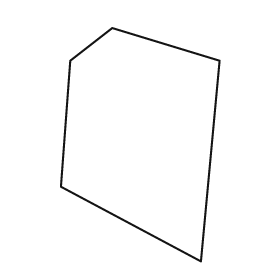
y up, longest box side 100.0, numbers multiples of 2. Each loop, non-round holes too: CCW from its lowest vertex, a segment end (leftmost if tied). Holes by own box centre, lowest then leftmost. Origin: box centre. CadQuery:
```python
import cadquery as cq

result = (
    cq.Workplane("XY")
    .moveTo(26.0, -50.0)
    .lineTo(34.0, 36.0)
    .lineTo(-12.0, 50.0)
    .lineTo(-30.0, 36.0)
    .lineTo(-34.0, -18.0)
    .close()
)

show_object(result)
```